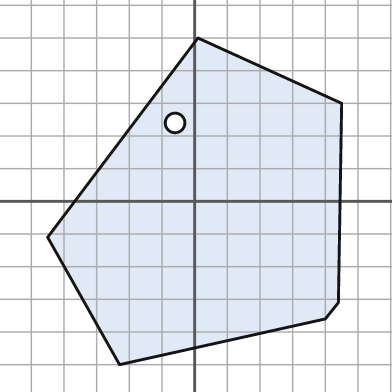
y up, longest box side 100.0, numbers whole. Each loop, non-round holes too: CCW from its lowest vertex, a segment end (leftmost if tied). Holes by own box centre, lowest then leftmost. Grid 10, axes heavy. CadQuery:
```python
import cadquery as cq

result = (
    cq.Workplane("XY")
    .moveTo(-23.0, -50.0)
    .lineTo(40.0, -36.0)
    .lineTo(44.0, -31.0)
    .lineTo(45.0, 30.0)
    .lineTo(1.0, 50.0)
    .lineTo(-45.0, -11.0)
    .close()
    .moveTo(-6.0, 24.0)
    .circle(3.0)
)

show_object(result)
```